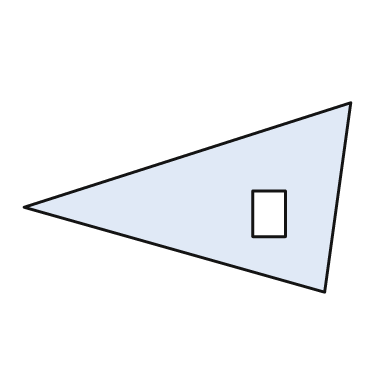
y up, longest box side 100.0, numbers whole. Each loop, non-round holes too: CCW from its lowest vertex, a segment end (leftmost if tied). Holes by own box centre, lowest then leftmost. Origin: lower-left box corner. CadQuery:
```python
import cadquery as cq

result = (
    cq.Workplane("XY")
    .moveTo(92.0, 0.0)
    .lineTo(100.0, 58.0)
    .lineTo(0.0, 26.0)
    .close()
    .moveTo(70.0, 17.0)
    .lineTo(80.0, 17.0)
    .lineTo(80.0, 31.0)
    .lineTo(70.0, 31.0)
    .close()
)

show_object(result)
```